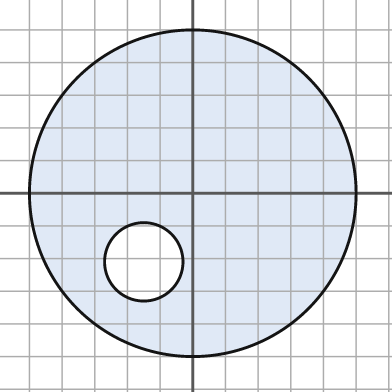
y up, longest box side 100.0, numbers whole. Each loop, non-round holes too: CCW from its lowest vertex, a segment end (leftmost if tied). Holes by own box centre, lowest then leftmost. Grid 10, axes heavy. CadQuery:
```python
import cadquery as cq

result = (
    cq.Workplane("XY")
    .moveTo(0.0, 0.0)
    .circle(50.0)
    .moveTo(-15.0, -21.0)
    .circle(12.0)
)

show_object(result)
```